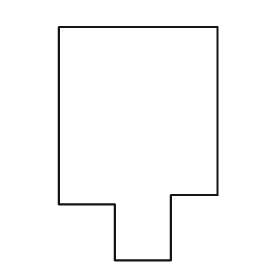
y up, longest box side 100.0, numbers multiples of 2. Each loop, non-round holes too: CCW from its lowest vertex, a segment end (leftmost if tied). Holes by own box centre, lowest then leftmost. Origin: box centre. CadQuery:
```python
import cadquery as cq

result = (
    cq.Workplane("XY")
    .moveTo(-10.0, -50.0)
    .lineTo(14.0, -50.0)
    .lineTo(14.0, -22.0)
    .lineTo(34.0, -22.0)
    .lineTo(34.0, 50.0)
    .lineTo(-34.0, 50.0)
    .lineTo(-34.0, -26.0)
    .lineTo(-10.0, -26.0)
    .close()
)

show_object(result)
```